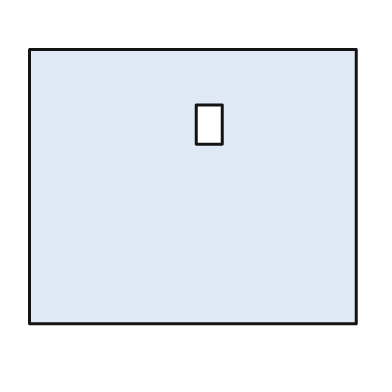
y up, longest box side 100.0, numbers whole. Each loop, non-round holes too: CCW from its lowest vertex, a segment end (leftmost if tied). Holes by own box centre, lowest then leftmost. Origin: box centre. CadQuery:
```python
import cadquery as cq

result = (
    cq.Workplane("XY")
    .moveTo(-50.0, -42.0)
    .lineTo(50.0, -42.0)
    .lineTo(50.0, 42.0)
    .lineTo(-50.0, 42.0)
    .close()
    .moveTo(1.0, 13.0)
    .lineTo(9.0, 13.0)
    .lineTo(9.0, 25.0)
    .lineTo(1.0, 25.0)
    .close()
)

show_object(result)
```